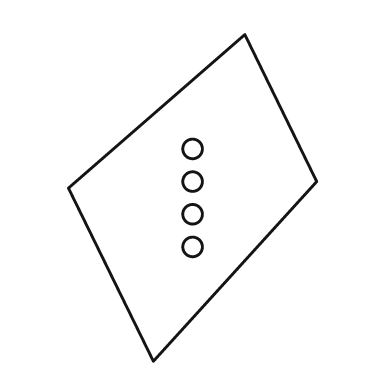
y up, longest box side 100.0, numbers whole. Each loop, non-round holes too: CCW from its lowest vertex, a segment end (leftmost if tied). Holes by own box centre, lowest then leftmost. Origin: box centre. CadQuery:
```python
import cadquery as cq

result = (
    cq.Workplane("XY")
    .moveTo(-12.0, -50.0)
    .lineTo(38.0, 5.0)
    .lineTo(16.0, 50.0)
    .lineTo(-38.0, 3.0)
    .close()
    .moveTo(0.0, -15.0)
    .circle(3.0)
    .moveTo(0.0, -5.0)
    .circle(3.0)
    .moveTo(0.0, 5.0)
    .circle(3.0)
    .moveTo(0.0, 15.0)
    .circle(3.0)
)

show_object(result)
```